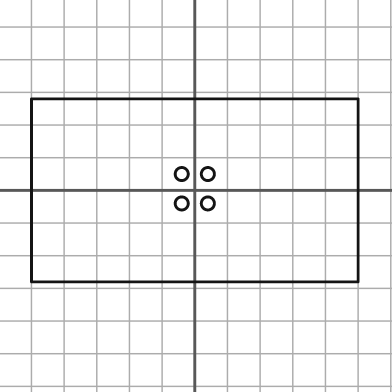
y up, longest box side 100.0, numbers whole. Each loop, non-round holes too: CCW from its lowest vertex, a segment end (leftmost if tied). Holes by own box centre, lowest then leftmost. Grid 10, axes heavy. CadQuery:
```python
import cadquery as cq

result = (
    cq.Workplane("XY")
    .moveTo(-50.0, -28.0)
    .lineTo(50.0, -28.0)
    .lineTo(50.0, 28.0)
    .lineTo(-50.0, 28.0)
    .close()
    .moveTo(-4.0, -4.0)
    .circle(2.0)
    .moveTo(4.0, -4.0)
    .circle(2.0)
    .moveTo(-4.0, 5.0)
    .circle(2.0)
    .moveTo(4.0, 5.0)
    .circle(2.0)
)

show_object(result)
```